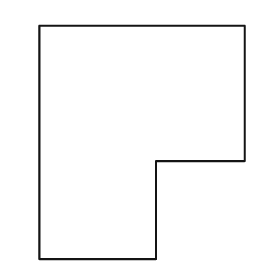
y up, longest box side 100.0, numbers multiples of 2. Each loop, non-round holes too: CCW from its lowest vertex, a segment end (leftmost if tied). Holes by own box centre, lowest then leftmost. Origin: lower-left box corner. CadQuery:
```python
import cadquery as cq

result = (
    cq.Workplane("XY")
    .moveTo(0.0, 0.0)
    .lineTo(50.0, 0.0)
    .lineTo(50.0, 42.0)
    .lineTo(88.0, 42.0)
    .lineTo(88.0, 100.0)
    .lineTo(0.0, 100.0)
    .close()
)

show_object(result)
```